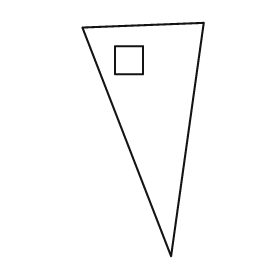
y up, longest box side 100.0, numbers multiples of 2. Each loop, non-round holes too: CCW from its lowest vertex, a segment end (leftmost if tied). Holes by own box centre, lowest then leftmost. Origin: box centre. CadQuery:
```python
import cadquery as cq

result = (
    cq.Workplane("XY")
    .moveTo(12.0, -50.0)
    .lineTo(26.0, 50.0)
    .lineTo(-26.0, 48.0)
    .close()
    .moveTo(-12.0, 28.0)
    .lineTo(0.0, 28.0)
    .lineTo(0.0, 40.0)
    .lineTo(-12.0, 40.0)
    .close()
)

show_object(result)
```